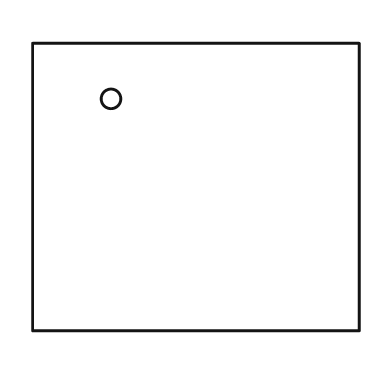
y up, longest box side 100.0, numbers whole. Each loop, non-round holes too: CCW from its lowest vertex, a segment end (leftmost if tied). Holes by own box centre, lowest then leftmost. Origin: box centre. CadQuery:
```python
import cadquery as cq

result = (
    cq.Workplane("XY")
    .moveTo(-50.0, -44.0)
    .lineTo(50.0, -44.0)
    .lineTo(50.0, 44.0)
    .lineTo(-50.0, 44.0)
    .close()
    .moveTo(-26.0, 27.0)
    .circle(3.0)
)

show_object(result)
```